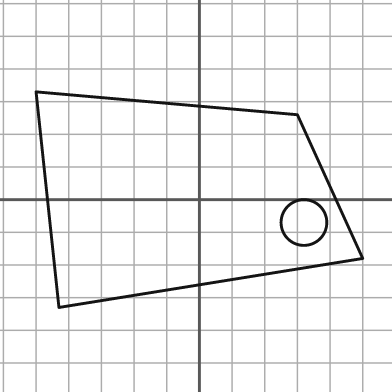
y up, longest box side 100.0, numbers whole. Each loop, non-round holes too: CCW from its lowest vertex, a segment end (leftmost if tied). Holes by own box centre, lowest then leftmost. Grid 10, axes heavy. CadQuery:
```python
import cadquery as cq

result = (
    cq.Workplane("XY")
    .moveTo(-43.0, -33.0)
    .lineTo(50.0, -18.0)
    .lineTo(30.0, 26.0)
    .lineTo(-50.0, 33.0)
    .close()
    .moveTo(32.0, -7.0)
    .circle(7.0)
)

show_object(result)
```